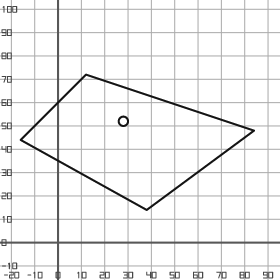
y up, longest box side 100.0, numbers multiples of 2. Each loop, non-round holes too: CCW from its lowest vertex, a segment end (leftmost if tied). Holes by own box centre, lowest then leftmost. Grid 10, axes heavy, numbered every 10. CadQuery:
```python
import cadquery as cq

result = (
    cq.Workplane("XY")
    .moveTo(38.0, 14.0)
    .lineTo(84.0, 48.0)
    .lineTo(12.0, 72.0)
    .lineTo(-16.0, 44.0)
    .close()
    .moveTo(28.0, 52.0)
    .circle(2.0)
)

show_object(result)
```